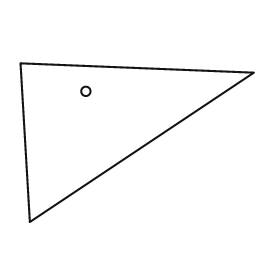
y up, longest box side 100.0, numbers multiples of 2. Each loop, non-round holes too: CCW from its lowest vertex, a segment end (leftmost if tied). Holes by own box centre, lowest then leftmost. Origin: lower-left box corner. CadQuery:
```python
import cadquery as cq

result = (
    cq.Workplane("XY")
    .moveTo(4.0, 0.0)
    .lineTo(100.0, 64.0)
    .lineTo(0.0, 68.0)
    .close()
    .moveTo(28.0, 56.0)
    .circle(2.0)
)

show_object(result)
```